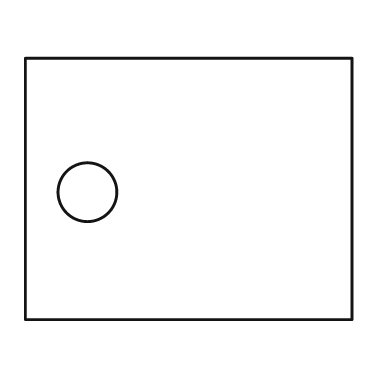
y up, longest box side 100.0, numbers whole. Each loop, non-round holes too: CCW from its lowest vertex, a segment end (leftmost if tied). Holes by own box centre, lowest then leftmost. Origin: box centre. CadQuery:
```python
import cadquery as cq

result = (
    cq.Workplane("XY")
    .moveTo(-50.0, -40.0)
    .lineTo(50.0, -40.0)
    .lineTo(50.0, 40.0)
    .lineTo(-50.0, 40.0)
    .close()
    .moveTo(-31.0, -1.0)
    .circle(9.0)
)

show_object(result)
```